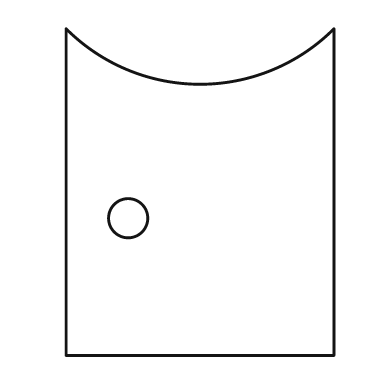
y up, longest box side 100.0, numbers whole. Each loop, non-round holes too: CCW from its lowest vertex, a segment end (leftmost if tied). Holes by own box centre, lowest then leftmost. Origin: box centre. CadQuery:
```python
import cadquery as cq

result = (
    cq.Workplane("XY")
    .moveTo(-41.0, -50.0)
    .lineTo(41.0, -50.0)
    .lineTo(41.0, 50.0)
    .threePointArc((0.0, 33.0), (-41.0, 50.0))
    .close()
    .moveTo(-22.0, -8.0)
    .circle(6.0)
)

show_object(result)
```